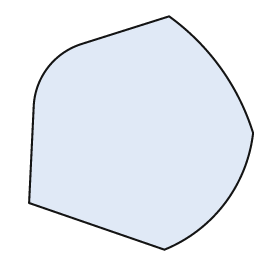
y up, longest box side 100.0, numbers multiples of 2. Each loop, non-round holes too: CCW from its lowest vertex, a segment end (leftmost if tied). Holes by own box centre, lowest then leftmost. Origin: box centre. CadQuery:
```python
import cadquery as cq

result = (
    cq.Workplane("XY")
    .moveTo(10.0, -50.0)
    .threePointArc((36.0, -30.0), (48.0, 0.0))
    .threePointArc((34.0, 28.0), (12.0, 50.0))
    .lineTo(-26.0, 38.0)
    .threePointArc((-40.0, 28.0), (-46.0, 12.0))
    .lineTo(-48.0, -30.0)
    .close()
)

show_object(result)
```